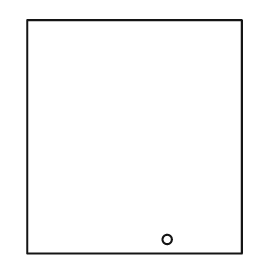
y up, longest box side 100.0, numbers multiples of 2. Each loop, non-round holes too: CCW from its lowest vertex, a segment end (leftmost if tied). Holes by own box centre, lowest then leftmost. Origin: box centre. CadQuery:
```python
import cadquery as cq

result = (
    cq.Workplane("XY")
    .moveTo(-46.0, -50.0)
    .lineTo(46.0, -50.0)
    .lineTo(46.0, 50.0)
    .lineTo(-46.0, 50.0)
    .close()
    .moveTo(14.0, -44.0)
    .circle(2.0)
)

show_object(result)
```